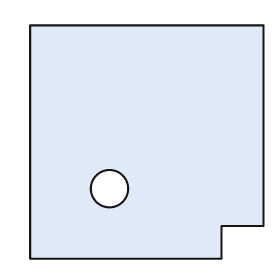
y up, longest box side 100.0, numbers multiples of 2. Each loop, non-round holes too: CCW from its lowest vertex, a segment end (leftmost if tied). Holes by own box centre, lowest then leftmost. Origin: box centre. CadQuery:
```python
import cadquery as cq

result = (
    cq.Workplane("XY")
    .moveTo(-50.0, -50.0)
    .lineTo(32.0, -50.0)
    .lineTo(32.0, -36.0)
    .lineTo(50.0, -36.0)
    .lineTo(50.0, 50.0)
    .lineTo(-50.0, 50.0)
    .close()
    .moveTo(-16.0, -20.0)
    .circle(8.0)
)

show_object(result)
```